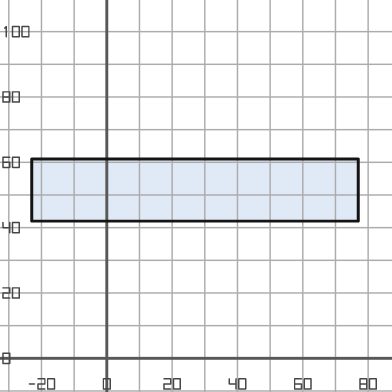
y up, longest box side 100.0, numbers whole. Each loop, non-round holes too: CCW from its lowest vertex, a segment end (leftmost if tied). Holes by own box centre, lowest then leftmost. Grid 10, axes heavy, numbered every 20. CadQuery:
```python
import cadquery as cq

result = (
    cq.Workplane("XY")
    .moveTo(-23.0, 42.0)
    .lineTo(77.0, 42.0)
    .lineTo(77.0, 61.0)
    .lineTo(-23.0, 61.0)
    .close()
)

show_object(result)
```